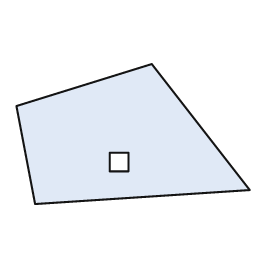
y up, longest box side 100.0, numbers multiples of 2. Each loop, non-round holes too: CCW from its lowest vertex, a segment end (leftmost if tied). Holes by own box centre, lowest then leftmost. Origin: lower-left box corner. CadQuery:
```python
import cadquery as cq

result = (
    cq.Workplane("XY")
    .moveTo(8.0, 0.0)
    .lineTo(100.0, 6.0)
    .lineTo(58.0, 60.0)
    .lineTo(0.0, 42.0)
    .close()
    .moveTo(40.0, 14.0)
    .lineTo(48.0, 14.0)
    .lineTo(48.0, 22.0)
    .lineTo(40.0, 22.0)
    .close()
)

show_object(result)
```